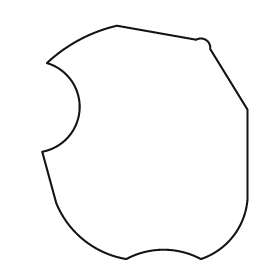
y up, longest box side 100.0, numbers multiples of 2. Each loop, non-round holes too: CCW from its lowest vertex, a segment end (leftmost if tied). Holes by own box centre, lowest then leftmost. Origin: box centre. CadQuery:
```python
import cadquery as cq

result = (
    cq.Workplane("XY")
    .moveTo(-8.0, -50.0)
    .threePointArc((8.0, -46.0), (24.0, -50.0))
    .threePointArc((38.0, -40.0), (44.0, -24.0))
    .lineTo(44.0, 14.0)
    .lineTo(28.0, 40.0)
    .threePointArc((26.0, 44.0), (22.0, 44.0))
    .lineTo(-12.0, 50.0)
    .threePointArc((-28.0, 44.0), (-42.0, 34.0))
    .threePointArc((-28.0, 14.0), (-44.0, -4.0))
    .lineTo(-38.0, -26.0)
    .threePointArc((-26.0, -42.0), (-8.0, -50.0))
    .close()
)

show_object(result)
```